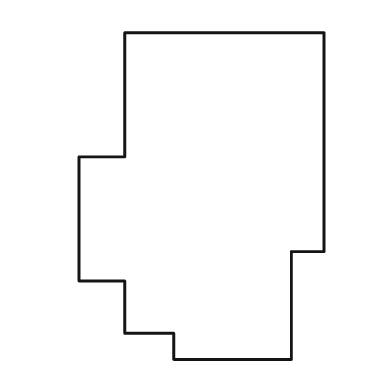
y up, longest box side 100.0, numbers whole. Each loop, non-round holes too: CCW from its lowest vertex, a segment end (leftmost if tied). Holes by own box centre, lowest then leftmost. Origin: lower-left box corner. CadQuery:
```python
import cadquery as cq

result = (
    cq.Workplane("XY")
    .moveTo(29.0, 0.0)
    .lineTo(65.0, 0.0)
    .lineTo(65.0, 33.0)
    .lineTo(75.0, 33.0)
    .lineTo(75.0, 100.0)
    .lineTo(14.0, 100.0)
    .lineTo(14.0, 62.0)
    .lineTo(0.0, 62.0)
    .lineTo(0.0, 24.0)
    .lineTo(14.0, 24.0)
    .lineTo(14.0, 8.0)
    .lineTo(29.0, 8.0)
    .close()
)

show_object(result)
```